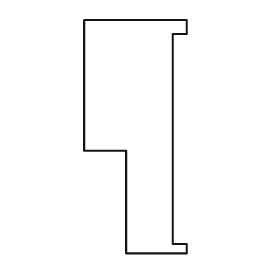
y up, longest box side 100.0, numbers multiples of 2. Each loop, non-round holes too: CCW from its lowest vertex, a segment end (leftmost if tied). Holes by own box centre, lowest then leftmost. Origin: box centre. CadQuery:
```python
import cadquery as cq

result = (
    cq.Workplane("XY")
    .moveTo(-4.0, -50.0)
    .lineTo(22.0, -50.0)
    .lineTo(22.0, -46.0)
    .lineTo(16.0, -46.0)
    .lineTo(16.0, 44.0)
    .lineTo(22.0, 44.0)
    .lineTo(22.0, 50.0)
    .lineTo(-22.0, 50.0)
    .lineTo(-22.0, -6.0)
    .lineTo(-4.0, -6.0)
    .close()
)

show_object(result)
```